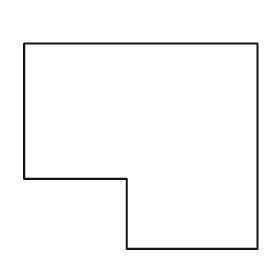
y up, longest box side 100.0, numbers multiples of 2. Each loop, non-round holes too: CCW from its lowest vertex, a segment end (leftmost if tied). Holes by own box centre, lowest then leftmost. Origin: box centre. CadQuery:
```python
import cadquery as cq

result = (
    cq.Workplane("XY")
    .moveTo(-6.0, -44.0)
    .lineTo(50.0, -44.0)
    .lineTo(50.0, 44.0)
    .lineTo(-50.0, 44.0)
    .lineTo(-50.0, -14.0)
    .lineTo(-6.0, -14.0)
    .close()
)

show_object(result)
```